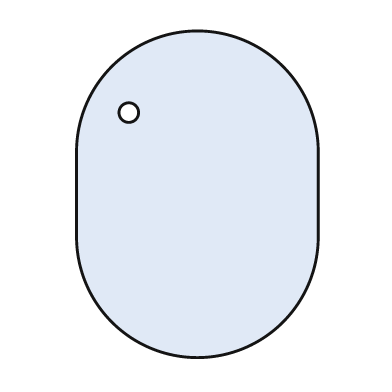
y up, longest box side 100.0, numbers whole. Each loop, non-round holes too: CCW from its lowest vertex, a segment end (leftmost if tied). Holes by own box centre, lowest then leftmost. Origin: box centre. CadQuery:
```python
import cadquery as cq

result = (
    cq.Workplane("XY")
    .moveTo(-37.0, -13.0)
    .threePointArc((0.0, -50.0), (37.0, -13.0))
    .lineTo(37.0, 13.0)
    .threePointArc((0.0, 50.0), (-37.0, 13.0))
    .close()
    .moveTo(-21.0, 25.0)
    .circle(3.0)
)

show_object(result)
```